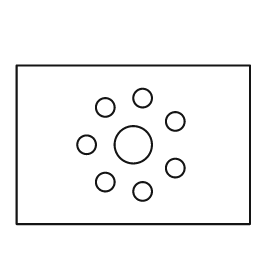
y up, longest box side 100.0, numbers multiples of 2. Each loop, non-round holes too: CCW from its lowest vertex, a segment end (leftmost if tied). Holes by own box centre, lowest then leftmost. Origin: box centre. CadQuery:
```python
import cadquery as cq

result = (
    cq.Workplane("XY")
    .moveTo(-50.0, -34.0)
    .lineTo(50.0, -34.0)
    .lineTo(50.0, 34.0)
    .lineTo(-50.0, 34.0)
    .close()
    .moveTo(4.0, -20.0)
    .circle(4.0)
    .moveTo(-12.0, -16.0)
    .circle(4.0)
    .moveTo(18.0, -10.0)
    .circle(4.0)
    .moveTo(-20.0, 0.0)
    .circle(4.0)
    .moveTo(0.0, 0.0)
    .circle(8.0)
    .moveTo(18.0, 10.0)
    .circle(4.0)
    .moveTo(-12.0, 16.0)
    .circle(4.0)
    .moveTo(4.0, 20.0)
    .circle(4.0)
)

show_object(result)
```